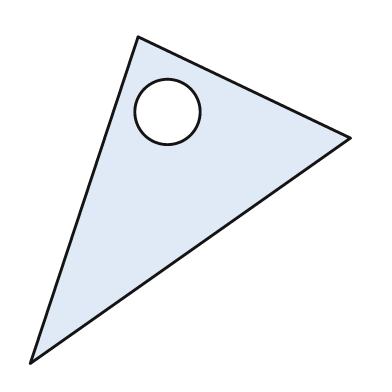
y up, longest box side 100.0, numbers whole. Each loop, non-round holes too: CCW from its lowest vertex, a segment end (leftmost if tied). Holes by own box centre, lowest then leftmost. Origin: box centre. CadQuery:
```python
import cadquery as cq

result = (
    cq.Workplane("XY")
    .moveTo(-49.0, -50.0)
    .lineTo(49.0, 19.0)
    .lineTo(-16.0, 50.0)
    .close()
    .moveTo(-7.0, 27.0)
    .circle(10.0)
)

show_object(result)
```